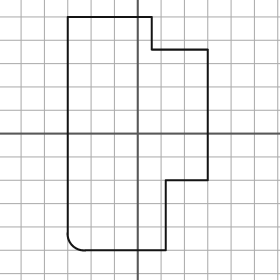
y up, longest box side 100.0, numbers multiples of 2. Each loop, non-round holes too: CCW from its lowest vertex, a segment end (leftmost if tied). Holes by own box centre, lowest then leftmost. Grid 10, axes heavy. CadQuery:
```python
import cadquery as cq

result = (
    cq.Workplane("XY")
    .moveTo(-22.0, -50.0)
    .lineTo(12.0, -50.0)
    .lineTo(12.0, -20.0)
    .lineTo(30.0, -20.0)
    .lineTo(30.0, 36.0)
    .lineTo(6.0, 36.0)
    .lineTo(6.0, 50.0)
    .lineTo(-30.0, 50.0)
    .lineTo(-30.0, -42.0)
    .threePointArc((-28.0, -48.0), (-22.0, -50.0))
    .close()
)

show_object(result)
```